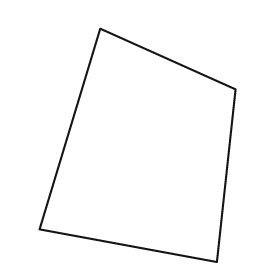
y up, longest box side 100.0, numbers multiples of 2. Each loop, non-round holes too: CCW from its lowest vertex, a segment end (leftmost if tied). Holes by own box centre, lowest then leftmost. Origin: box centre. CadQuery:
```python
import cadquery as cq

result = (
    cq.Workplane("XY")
    .moveTo(34.0, -50.0)
    .lineTo(42.0, 24.0)
    .lineTo(-16.0, 50.0)
    .lineTo(-42.0, -36.0)
    .close()
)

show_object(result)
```